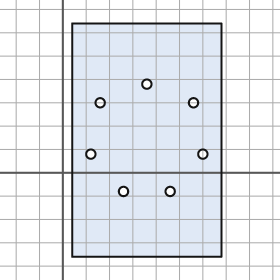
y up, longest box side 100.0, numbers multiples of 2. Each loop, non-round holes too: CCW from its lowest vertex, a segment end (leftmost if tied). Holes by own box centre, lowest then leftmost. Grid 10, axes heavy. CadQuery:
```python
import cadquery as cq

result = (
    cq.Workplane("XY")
    .moveTo(4.0, -36.0)
    .lineTo(68.0, -36.0)
    .lineTo(68.0, 64.0)
    .lineTo(4.0, 64.0)
    .close()
    .moveTo(26.0, -8.0)
    .circle(2.0)
    .moveTo(46.0, -8.0)
    .circle(2.0)
    .moveTo(12.0, 8.0)
    .circle(2.0)
    .moveTo(60.0, 8.0)
    .circle(2.0)
    .moveTo(16.0, 30.0)
    .circle(2.0)
    .moveTo(56.0, 30.0)
    .circle(2.0)
    .moveTo(36.0, 38.0)
    .circle(2.0)
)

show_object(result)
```